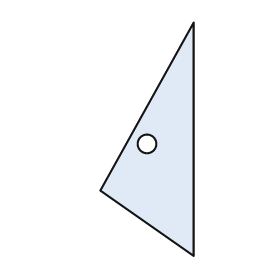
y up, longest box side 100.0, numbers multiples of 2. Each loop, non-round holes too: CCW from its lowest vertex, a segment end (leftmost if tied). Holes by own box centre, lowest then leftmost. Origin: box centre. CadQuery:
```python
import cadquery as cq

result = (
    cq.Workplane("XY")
    .moveTo(20.0, -50.0)
    .lineTo(20.0, 50.0)
    .lineTo(-20.0, -22.0)
    .close()
    .moveTo(0.0, -2.0)
    .circle(4.0)
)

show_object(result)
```